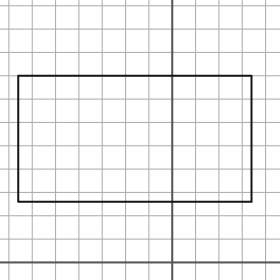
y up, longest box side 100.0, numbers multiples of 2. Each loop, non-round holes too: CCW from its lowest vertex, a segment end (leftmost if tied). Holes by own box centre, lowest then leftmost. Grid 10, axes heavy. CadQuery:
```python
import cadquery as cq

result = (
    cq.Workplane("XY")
    .moveTo(-66.0, 26.0)
    .lineTo(34.0, 26.0)
    .lineTo(34.0, 80.0)
    .lineTo(-66.0, 80.0)
    .close()
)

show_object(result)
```